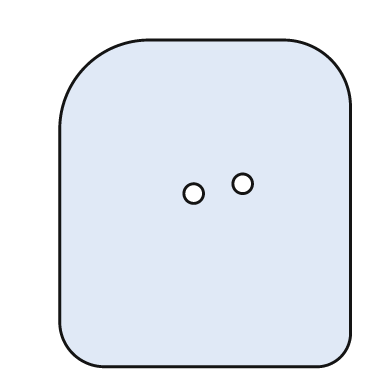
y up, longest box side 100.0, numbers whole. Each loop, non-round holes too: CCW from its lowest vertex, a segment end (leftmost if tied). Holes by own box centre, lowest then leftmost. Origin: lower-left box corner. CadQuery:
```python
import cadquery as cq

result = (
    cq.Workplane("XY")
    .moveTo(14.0, 0.0)
    .lineTo(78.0, 0.0)
    .threePointArc((86.0, 3.0), (89.0, 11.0))
    .lineTo(89.0, 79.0)
    .threePointArc((83.0, 94.0), (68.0, 100.0))
    .lineTo(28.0, 100.0)
    .threePointArc((8.0, 92.0), (0.0, 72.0))
    .lineTo(0.0, 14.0)
    .threePointArc((4.0, 4.0), (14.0, 0.0))
    .close()
    .moveTo(41.0, 53.0)
    .circle(3.0)
    .moveTo(56.0, 56.0)
    .circle(3.0)
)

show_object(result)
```